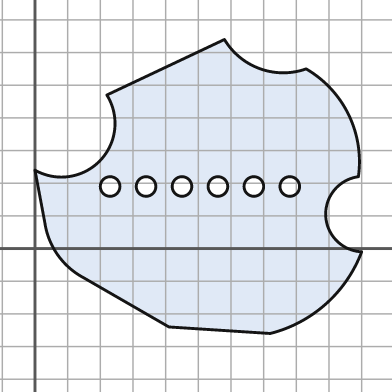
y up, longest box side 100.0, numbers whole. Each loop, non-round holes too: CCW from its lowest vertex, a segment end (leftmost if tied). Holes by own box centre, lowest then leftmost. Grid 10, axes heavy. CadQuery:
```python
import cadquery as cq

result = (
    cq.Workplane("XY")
    .moveTo(72.0, -26.0)
    .threePointArc((89.0, -17.0), (100.0, -1.0))
    .threePointArc((89.0, 10.0), (99.0, 22.0))
    .threePointArc((96.0, 41.0), (83.0, 55.0))
    .threePointArc((69.0, 55.0), (58.0, 64.0))
    .lineTo(22.0, 47.0)
    .threePointArc((20.0, 27.0), (0.0, 24.0))
    .lineTo(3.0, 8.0)
    .threePointArc((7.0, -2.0), (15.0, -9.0))
    .lineTo(41.0, -24.0)
    .close()
    .moveTo(23.0, 19.0)
    .circle(3.0)
    .moveTo(34.0, 19.0)
    .circle(3.0)
    .moveTo(45.0, 19.0)
    .circle(3.0)
    .moveTo(56.0, 19.0)
    .circle(3.0)
    .moveTo(67.0, 19.0)
    .circle(3.0)
    .moveTo(78.0, 19.0)
    .circle(3.0)
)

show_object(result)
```